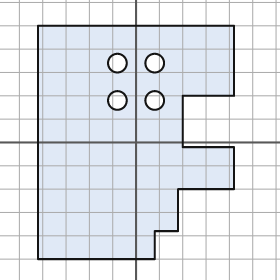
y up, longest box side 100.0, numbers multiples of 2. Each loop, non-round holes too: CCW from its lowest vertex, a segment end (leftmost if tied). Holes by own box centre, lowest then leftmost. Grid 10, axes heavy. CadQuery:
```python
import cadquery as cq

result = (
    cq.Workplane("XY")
    .moveTo(-42.0, -50.0)
    .lineTo(8.0, -50.0)
    .lineTo(8.0, -38.0)
    .lineTo(18.0, -38.0)
    .lineTo(18.0, -20.0)
    .lineTo(42.0, -20.0)
    .lineTo(42.0, -2.0)
    .lineTo(20.0, -2.0)
    .lineTo(20.0, 20.0)
    .lineTo(42.0, 20.0)
    .lineTo(42.0, 50.0)
    .lineTo(-42.0, 50.0)
    .close()
    .moveTo(-8.0, 18.0)
    .circle(4.0)
    .moveTo(8.0, 18.0)
    .circle(4.0)
    .moveTo(-8.0, 34.0)
    .circle(4.0)
    .moveTo(8.0, 34.0)
    .circle(4.0)
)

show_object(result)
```